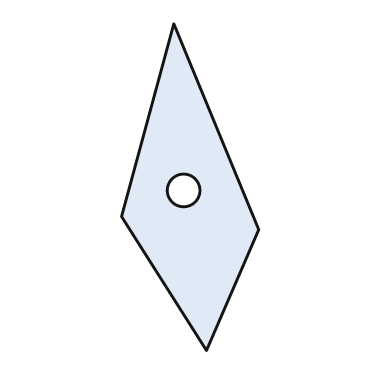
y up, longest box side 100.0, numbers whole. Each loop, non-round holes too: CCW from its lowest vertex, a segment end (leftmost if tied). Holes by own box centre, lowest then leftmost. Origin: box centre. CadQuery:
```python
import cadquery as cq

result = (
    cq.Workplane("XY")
    .moveTo(5.0, -50.0)
    .lineTo(21.0, -13.0)
    .lineTo(-5.0, 50.0)
    .lineTo(-21.0, -9.0)
    .close()
    .moveTo(-2.0, -1.0)
    .circle(5.0)
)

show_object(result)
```